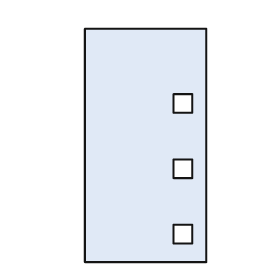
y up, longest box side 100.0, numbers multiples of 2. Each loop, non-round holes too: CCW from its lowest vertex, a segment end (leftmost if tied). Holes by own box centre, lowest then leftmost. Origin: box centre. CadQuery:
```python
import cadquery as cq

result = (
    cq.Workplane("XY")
    .moveTo(-26.0, -50.0)
    .lineTo(26.0, -50.0)
    .lineTo(26.0, 50.0)
    .lineTo(-26.0, 50.0)
    .close()
    .moveTo(12.0, -42.0)
    .lineTo(20.0, -42.0)
    .lineTo(20.0, -34.0)
    .lineTo(12.0, -34.0)
    .close()
    .moveTo(12.0, -14.0)
    .lineTo(20.0, -14.0)
    .lineTo(20.0, -6.0)
    .lineTo(12.0, -6.0)
    .close()
    .moveTo(12.0, 14.0)
    .lineTo(20.0, 14.0)
    .lineTo(20.0, 22.0)
    .lineTo(12.0, 22.0)
    .close()
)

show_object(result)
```